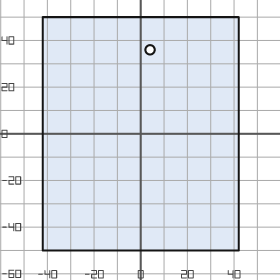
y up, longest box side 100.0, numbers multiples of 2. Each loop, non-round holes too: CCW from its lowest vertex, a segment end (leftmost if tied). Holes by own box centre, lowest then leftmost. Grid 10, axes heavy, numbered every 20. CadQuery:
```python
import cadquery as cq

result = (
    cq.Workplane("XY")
    .moveTo(-42.0, -50.0)
    .lineTo(42.0, -50.0)
    .lineTo(42.0, 50.0)
    .lineTo(-42.0, 50.0)
    .close()
    .moveTo(4.0, 36.0)
    .circle(2.0)
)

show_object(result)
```